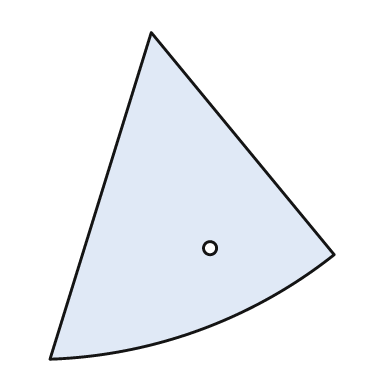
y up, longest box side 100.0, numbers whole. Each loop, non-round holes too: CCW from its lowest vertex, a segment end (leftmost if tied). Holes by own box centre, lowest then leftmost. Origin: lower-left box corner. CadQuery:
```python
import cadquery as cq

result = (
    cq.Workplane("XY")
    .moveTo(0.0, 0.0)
    .threePointArc((46.0, 9.0), (87.0, 32.0))
    .lineTo(31.0, 100.0)
    .close()
    .moveTo(49.0, 34.0)
    .circle(2.0)
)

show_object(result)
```